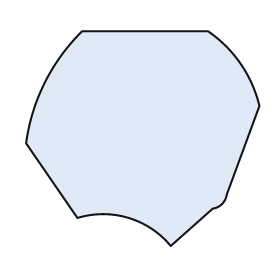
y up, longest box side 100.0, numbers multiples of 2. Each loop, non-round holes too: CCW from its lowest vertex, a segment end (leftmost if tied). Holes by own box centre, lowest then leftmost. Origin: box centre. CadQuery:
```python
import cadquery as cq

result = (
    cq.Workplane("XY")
    .moveTo(12.0, -46.0)
    .lineTo(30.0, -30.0)
    .threePointArc((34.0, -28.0), (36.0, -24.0))
    .lineTo(50.0, 14.0)
    .threePointArc((42.0, 32.0), (28.0, 46.0))
    .lineTo(-26.0, 46.0)
    .threePointArc((-42.0, 24.0), (-50.0, -2.0))
    .lineTo(-28.0, -34.0)
    .threePointArc((-6.0, -34.0), (12.0, -46.0))
    .close()
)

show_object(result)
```